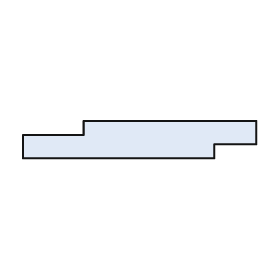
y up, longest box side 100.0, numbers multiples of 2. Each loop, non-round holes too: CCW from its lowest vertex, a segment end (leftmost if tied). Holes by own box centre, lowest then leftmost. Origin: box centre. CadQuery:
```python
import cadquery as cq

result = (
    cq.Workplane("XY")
    .moveTo(-50.0, -8.0)
    .lineTo(32.0, -8.0)
    .lineTo(32.0, -2.0)
    .lineTo(50.0, -2.0)
    .lineTo(50.0, 8.0)
    .lineTo(-24.0, 8.0)
    .lineTo(-24.0, 2.0)
    .lineTo(-50.0, 2.0)
    .close()
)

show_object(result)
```